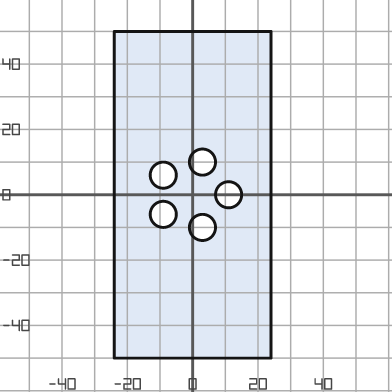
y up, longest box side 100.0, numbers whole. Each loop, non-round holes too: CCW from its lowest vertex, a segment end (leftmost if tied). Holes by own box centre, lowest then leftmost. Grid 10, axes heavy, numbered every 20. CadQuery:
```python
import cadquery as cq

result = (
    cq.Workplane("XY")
    .moveTo(-24.0, -50.0)
    .lineTo(24.0, -50.0)
    .lineTo(24.0, 50.0)
    .lineTo(-24.0, 50.0)
    .close()
    .moveTo(3.0, -10.0)
    .circle(4.0)
    .moveTo(-9.0, -6.0)
    .circle(4.0)
    .moveTo(11.0, 0.0)
    .circle(4.0)
    .moveTo(-9.0, 6.0)
    .circle(4.0)
    .moveTo(3.0, 10.0)
    .circle(4.0)
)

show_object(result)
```